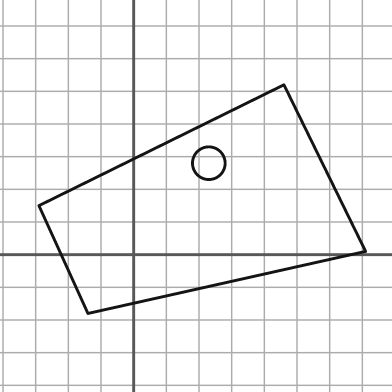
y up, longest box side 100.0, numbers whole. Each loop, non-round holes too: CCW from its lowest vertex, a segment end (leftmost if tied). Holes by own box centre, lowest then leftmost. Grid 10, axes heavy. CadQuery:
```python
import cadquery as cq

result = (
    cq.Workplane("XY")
    .moveTo(-14.0, -18.0)
    .lineTo(71.0, 1.0)
    .lineTo(46.0, 52.0)
    .lineTo(-29.0, 15.0)
    .close()
    .moveTo(23.0, 28.0)
    .circle(5.0)
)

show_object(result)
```